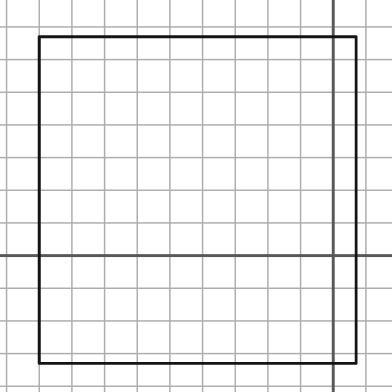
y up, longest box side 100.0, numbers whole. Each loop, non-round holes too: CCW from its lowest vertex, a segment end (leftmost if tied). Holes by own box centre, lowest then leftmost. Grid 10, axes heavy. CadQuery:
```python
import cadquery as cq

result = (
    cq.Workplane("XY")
    .moveTo(-90.0, -33.0)
    .lineTo(7.0, -33.0)
    .lineTo(7.0, 67.0)
    .lineTo(-90.0, 67.0)
    .close()
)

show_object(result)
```